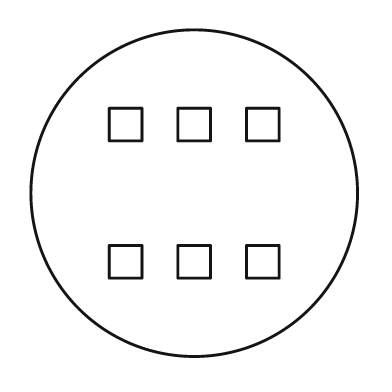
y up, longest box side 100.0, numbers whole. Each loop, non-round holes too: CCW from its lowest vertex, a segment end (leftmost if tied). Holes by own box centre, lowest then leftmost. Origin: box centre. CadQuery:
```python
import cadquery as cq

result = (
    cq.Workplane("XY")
    .moveTo(0.0, 0.0)
    .circle(50.0)
    .moveTo(-26.0, -26.0)
    .lineTo(-16.0, -26.0)
    .lineTo(-16.0, -16.0)
    .lineTo(-26.0, -16.0)
    .close()
    .moveTo(-5.0, -26.0)
    .lineTo(5.0, -26.0)
    .lineTo(5.0, -16.0)
    .lineTo(-5.0, -16.0)
    .close()
    .moveTo(16.0, -26.0)
    .lineTo(26.0, -26.0)
    .lineTo(26.0, -16.0)
    .lineTo(16.0, -16.0)
    .close()
    .moveTo(-26.0, 16.0)
    .lineTo(-16.0, 16.0)
    .lineTo(-16.0, 26.0)
    .lineTo(-26.0, 26.0)
    .close()
    .moveTo(-5.0, 16.0)
    .lineTo(5.0, 16.0)
    .lineTo(5.0, 26.0)
    .lineTo(-5.0, 26.0)
    .close()
    .moveTo(16.0, 16.0)
    .lineTo(26.0, 16.0)
    .lineTo(26.0, 26.0)
    .lineTo(16.0, 26.0)
    .close()
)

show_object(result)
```